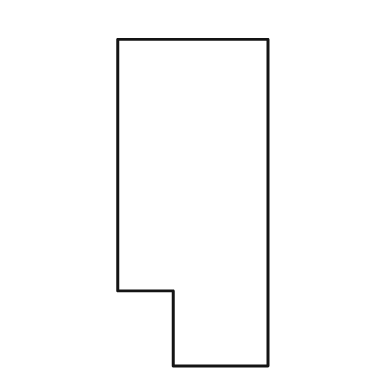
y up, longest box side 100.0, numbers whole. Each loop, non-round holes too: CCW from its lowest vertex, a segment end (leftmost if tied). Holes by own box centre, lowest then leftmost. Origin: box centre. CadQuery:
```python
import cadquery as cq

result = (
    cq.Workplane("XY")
    .moveTo(-6.0, -50.0)
    .lineTo(23.0, -50.0)
    .lineTo(23.0, 50.0)
    .lineTo(-23.0, 50.0)
    .lineTo(-23.0, -27.0)
    .lineTo(-6.0, -27.0)
    .close()
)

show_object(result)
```